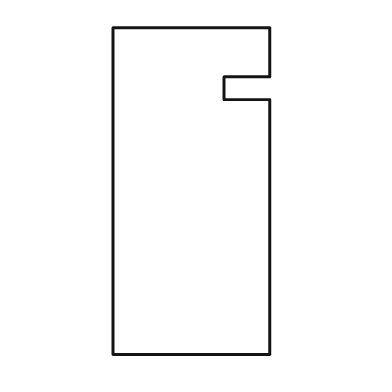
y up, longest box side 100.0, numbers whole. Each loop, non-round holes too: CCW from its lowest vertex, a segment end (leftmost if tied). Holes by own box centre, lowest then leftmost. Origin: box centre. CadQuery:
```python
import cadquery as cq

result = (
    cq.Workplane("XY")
    .moveTo(-24.0, -50.0)
    .lineTo(24.0, -50.0)
    .lineTo(24.0, 28.0)
    .lineTo(10.0, 28.0)
    .lineTo(10.0, 35.0)
    .lineTo(24.0, 35.0)
    .lineTo(24.0, 50.0)
    .lineTo(-24.0, 50.0)
    .close()
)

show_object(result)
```